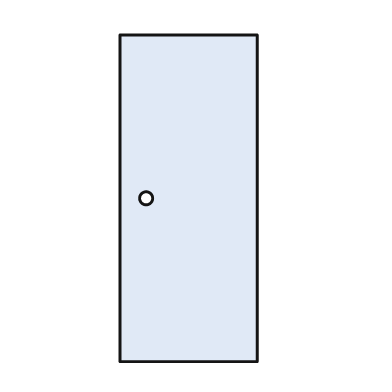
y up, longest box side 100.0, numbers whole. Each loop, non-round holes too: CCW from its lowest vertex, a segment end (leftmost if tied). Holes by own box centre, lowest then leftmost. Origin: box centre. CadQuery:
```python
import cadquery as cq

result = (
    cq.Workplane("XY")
    .moveTo(-21.0, -50.0)
    .lineTo(21.0, -50.0)
    .lineTo(21.0, 50.0)
    .lineTo(-21.0, 50.0)
    .close()
    .moveTo(-13.0, 0.0)
    .circle(2.0)
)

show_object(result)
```